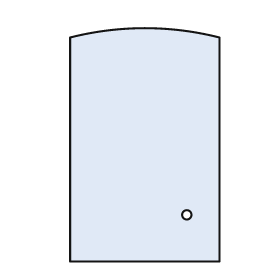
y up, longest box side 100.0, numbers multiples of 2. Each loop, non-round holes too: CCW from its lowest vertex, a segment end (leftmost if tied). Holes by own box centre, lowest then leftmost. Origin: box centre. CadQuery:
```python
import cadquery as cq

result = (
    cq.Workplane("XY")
    .moveTo(-32.0, -50.0)
    .lineTo(32.0, -50.0)
    .lineTo(32.0, 46.0)
    .threePointArc((0.0, 50.0), (-32.0, 46.0))
    .close()
    .moveTo(18.0, -30.0)
    .circle(2.0)
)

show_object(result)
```